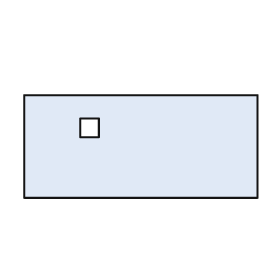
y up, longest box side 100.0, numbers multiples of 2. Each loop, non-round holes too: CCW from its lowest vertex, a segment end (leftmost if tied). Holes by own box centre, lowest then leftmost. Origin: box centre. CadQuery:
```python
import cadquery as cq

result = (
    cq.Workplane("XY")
    .moveTo(-50.0, -22.0)
    .lineTo(50.0, -22.0)
    .lineTo(50.0, 22.0)
    .lineTo(-50.0, 22.0)
    .close()
    .moveTo(-26.0, 4.0)
    .lineTo(-18.0, 4.0)
    .lineTo(-18.0, 12.0)
    .lineTo(-26.0, 12.0)
    .close()
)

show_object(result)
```